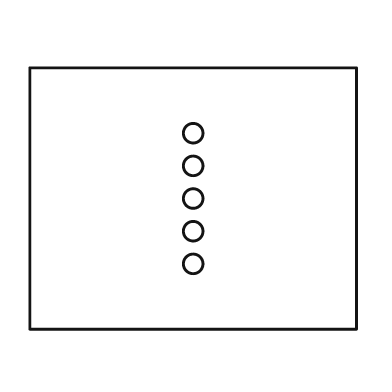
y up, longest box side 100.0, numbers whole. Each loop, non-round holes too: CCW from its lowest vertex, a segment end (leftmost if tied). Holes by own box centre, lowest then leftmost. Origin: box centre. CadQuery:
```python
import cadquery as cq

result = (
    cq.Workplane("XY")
    .moveTo(-50.0, -40.0)
    .lineTo(50.0, -40.0)
    .lineTo(50.0, 40.0)
    .lineTo(-50.0, 40.0)
    .close()
    .moveTo(0.0, -20.0)
    .circle(3.0)
    .moveTo(0.0, -10.0)
    .circle(3.0)
    .moveTo(0.0, 0.0)
    .circle(3.0)
    .moveTo(0.0, 10.0)
    .circle(3.0)
    .moveTo(0.0, 20.0)
    .circle(3.0)
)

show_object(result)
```